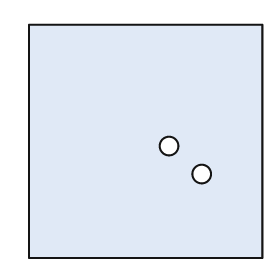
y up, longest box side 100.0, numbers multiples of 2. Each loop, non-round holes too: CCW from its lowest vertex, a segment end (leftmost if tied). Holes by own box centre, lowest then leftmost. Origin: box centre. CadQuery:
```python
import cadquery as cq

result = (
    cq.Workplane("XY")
    .moveTo(-50.0, -50.0)
    .lineTo(50.0, -50.0)
    .lineTo(50.0, 50.0)
    .lineTo(-50.0, 50.0)
    .close()
    .moveTo(24.0, -14.0)
    .circle(4.0)
    .moveTo(10.0, -2.0)
    .circle(4.0)
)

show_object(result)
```